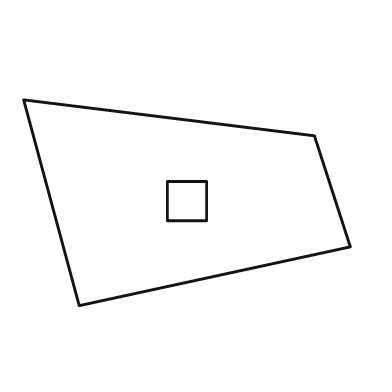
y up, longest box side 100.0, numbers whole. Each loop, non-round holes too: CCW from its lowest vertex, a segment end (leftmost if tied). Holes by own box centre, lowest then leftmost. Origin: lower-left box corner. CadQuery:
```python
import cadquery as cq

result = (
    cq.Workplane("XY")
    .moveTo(17.0, 0.0)
    .lineTo(100.0, 18.0)
    .lineTo(89.0, 52.0)
    .lineTo(0.0, 63.0)
    .close()
    .moveTo(44.0, 26.0)
    .lineTo(56.0, 26.0)
    .lineTo(56.0, 38.0)
    .lineTo(44.0, 38.0)
    .close()
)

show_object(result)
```